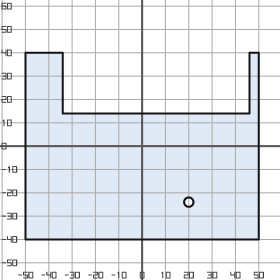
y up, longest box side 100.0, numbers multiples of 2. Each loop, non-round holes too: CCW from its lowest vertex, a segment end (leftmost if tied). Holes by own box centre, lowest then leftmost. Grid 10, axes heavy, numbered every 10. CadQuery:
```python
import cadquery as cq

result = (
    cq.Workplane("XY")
    .moveTo(-50.0, -40.0)
    .lineTo(50.0, -40.0)
    .lineTo(50.0, 40.0)
    .lineTo(46.0, 40.0)
    .lineTo(46.0, 14.0)
    .lineTo(-34.0, 14.0)
    .lineTo(-34.0, 40.0)
    .lineTo(-50.0, 40.0)
    .close()
    .moveTo(20.0, -24.0)
    .circle(2.0)
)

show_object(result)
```